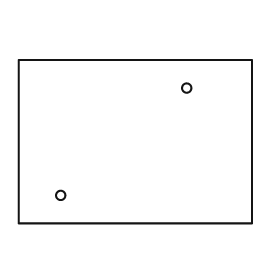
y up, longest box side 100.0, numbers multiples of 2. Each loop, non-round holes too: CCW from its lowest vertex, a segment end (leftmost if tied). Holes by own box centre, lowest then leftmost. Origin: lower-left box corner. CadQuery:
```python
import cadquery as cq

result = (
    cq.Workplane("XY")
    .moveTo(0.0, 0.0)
    .lineTo(100.0, 0.0)
    .lineTo(100.0, 70.0)
    .lineTo(0.0, 70.0)
    .close()
    .moveTo(18.0, 12.0)
    .circle(2.0)
    .moveTo(72.0, 58.0)
    .circle(2.0)
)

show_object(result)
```